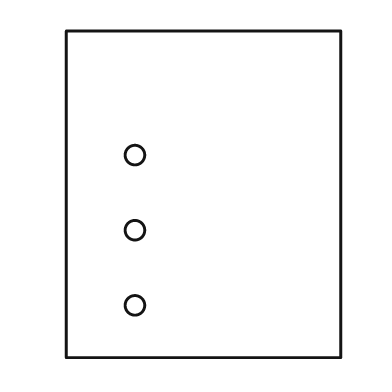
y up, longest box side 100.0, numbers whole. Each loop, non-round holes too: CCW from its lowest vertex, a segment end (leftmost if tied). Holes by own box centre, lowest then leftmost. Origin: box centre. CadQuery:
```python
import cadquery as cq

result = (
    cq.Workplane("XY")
    .moveTo(-42.0, -50.0)
    .lineTo(42.0, -50.0)
    .lineTo(42.0, 50.0)
    .lineTo(-42.0, 50.0)
    .close()
    .moveTo(-21.0, -34.0)
    .circle(3.0)
    .moveTo(-21.0, -11.0)
    .circle(3.0)
    .moveTo(-21.0, 12.0)
    .circle(3.0)
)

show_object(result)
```